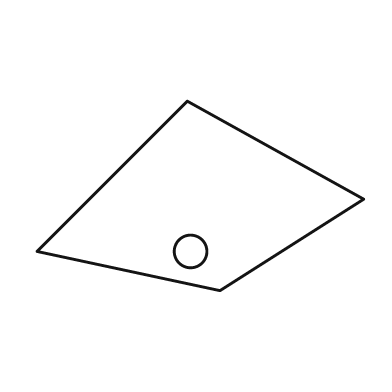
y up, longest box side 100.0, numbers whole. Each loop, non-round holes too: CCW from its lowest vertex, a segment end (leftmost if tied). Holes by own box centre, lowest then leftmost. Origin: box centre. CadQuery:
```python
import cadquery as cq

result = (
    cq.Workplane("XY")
    .moveTo(6.0, -29.0)
    .lineTo(50.0, -1.0)
    .lineTo(-4.0, 29.0)
    .lineTo(-50.0, -17.0)
    .close()
    .moveTo(-3.0, -17.0)
    .circle(5.0)
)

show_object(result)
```